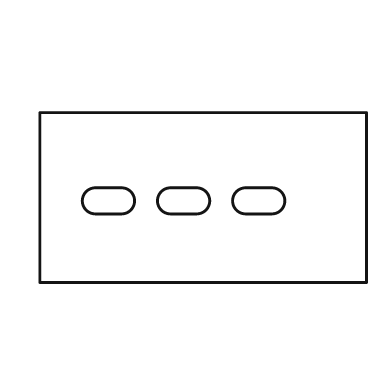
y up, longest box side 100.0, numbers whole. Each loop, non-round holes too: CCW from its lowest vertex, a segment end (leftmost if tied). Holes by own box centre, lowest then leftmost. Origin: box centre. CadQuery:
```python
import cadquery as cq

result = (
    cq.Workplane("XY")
    .moveTo(-50.0, -26.0)
    .lineTo(50.0, -26.0)
    .lineTo(50.0, 26.0)
    .lineTo(-50.0, 26.0)
    .close()
    .moveTo(-33.0, -5.0)
    .lineTo(-25.0, -5.0)
    .threePointArc((-21.0, -1.0), (-25.0, 3.0))
    .lineTo(-33.0, 3.0)
    .threePointArc((-37.0, -1.0), (-33.0, -5.0))
    .close()
    .moveTo(-10.0, -5.0)
    .lineTo(-2.0, -5.0)
    .threePointArc((2.0, -1.0), (-2.0, 3.0))
    .lineTo(-10.0, 3.0)
    .threePointArc((-14.0, -1.0), (-10.0, -5.0))
    .close()
    .moveTo(13.0, -5.0)
    .lineTo(21.0, -5.0)
    .threePointArc((25.0, -1.0), (21.0, 3.0))
    .lineTo(13.0, 3.0)
    .threePointArc((9.0, -1.0), (13.0, -5.0))
    .close()
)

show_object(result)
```